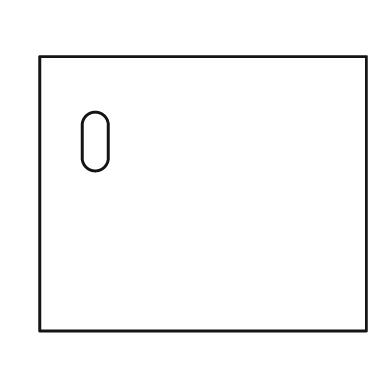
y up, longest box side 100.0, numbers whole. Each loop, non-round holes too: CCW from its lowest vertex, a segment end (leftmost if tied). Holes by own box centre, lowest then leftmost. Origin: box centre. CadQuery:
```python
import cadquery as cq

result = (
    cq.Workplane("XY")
    .moveTo(-50.0, -42.0)
    .lineTo(50.0, -42.0)
    .lineTo(50.0, 42.0)
    .lineTo(-50.0, 42.0)
    .close()
    .moveTo(-37.0, 11.0)
    .threePointArc((-33.0, 7.0), (-29.0, 11.0))
    .lineTo(-29.0, 21.0)
    .threePointArc((-33.0, 25.0), (-37.0, 21.0))
    .close()
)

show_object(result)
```